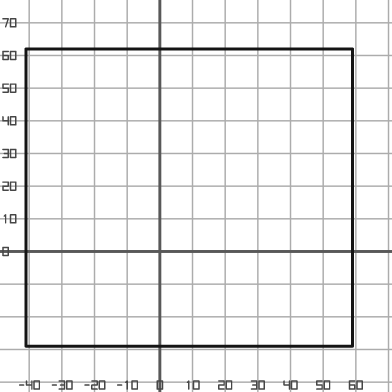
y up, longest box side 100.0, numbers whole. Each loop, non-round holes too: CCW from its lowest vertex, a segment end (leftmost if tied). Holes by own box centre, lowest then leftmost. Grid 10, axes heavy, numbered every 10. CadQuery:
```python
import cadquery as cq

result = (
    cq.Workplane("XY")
    .moveTo(-41.0, -29.0)
    .lineTo(59.0, -29.0)
    .lineTo(59.0, 62.0)
    .lineTo(-41.0, 62.0)
    .close()
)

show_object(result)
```